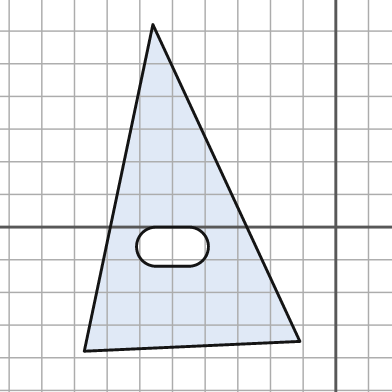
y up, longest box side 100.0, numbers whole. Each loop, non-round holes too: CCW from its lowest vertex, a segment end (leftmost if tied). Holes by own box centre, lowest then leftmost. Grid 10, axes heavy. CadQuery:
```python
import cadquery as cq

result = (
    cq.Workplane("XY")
    .moveTo(-77.0, -38.0)
    .lineTo(-11.0, -35.0)
    .lineTo(-56.0, 62.0)
    .close()
    .moveTo(-55.0, -12.0)
    .lineTo(-45.0, -12.0)
    .threePointArc((-39.0, -6.0), (-45.0, 0.0))
    .lineTo(-55.0, 0.0)
    .threePointArc((-61.0, -6.0), (-55.0, -12.0))
    .close()
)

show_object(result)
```